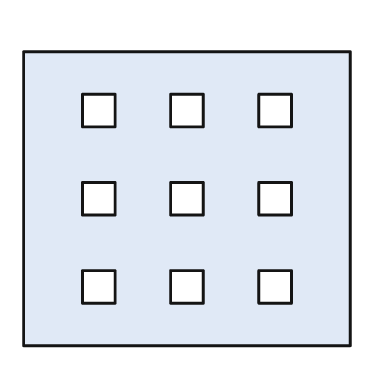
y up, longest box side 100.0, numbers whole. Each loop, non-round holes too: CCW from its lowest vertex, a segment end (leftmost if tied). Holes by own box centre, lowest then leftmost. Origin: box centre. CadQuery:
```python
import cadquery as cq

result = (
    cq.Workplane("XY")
    .moveTo(-50.0, -45.0)
    .lineTo(50.0, -45.0)
    .lineTo(50.0, 45.0)
    .lineTo(-50.0, 45.0)
    .close()
    .moveTo(-32.0, -32.0)
    .lineTo(-22.0, -32.0)
    .lineTo(-22.0, -22.0)
    .lineTo(-32.0, -22.0)
    .close()
    .moveTo(-5.0, -32.0)
    .lineTo(5.0, -32.0)
    .lineTo(5.0, -22.0)
    .lineTo(-5.0, -22.0)
    .close()
    .moveTo(22.0, -32.0)
    .lineTo(32.0, -32.0)
    .lineTo(32.0, -22.0)
    .lineTo(22.0, -22.0)
    .close()
    .moveTo(-32.0, -5.0)
    .lineTo(-22.0, -5.0)
    .lineTo(-22.0, 5.0)
    .lineTo(-32.0, 5.0)
    .close()
    .moveTo(-5.0, -5.0)
    .lineTo(5.0, -5.0)
    .lineTo(5.0, 5.0)
    .lineTo(-5.0, 5.0)
    .close()
    .moveTo(22.0, -5.0)
    .lineTo(32.0, -5.0)
    .lineTo(32.0, 5.0)
    .lineTo(22.0, 5.0)
    .close()
    .moveTo(-32.0, 22.0)
    .lineTo(-22.0, 22.0)
    .lineTo(-22.0, 32.0)
    .lineTo(-32.0, 32.0)
    .close()
    .moveTo(-5.0, 22.0)
    .lineTo(5.0, 22.0)
    .lineTo(5.0, 32.0)
    .lineTo(-5.0, 32.0)
    .close()
    .moveTo(22.0, 22.0)
    .lineTo(32.0, 22.0)
    .lineTo(32.0, 32.0)
    .lineTo(22.0, 32.0)
    .close()
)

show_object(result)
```